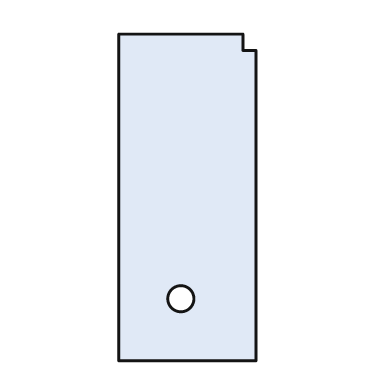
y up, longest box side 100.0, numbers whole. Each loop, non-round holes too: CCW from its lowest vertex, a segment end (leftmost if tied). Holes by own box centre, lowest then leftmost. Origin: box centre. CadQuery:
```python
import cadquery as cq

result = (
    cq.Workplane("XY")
    .moveTo(-21.0, -50.0)
    .lineTo(21.0, -50.0)
    .lineTo(21.0, 45.0)
    .lineTo(17.0, 45.0)
    .lineTo(17.0, 50.0)
    .lineTo(-21.0, 50.0)
    .close()
    .moveTo(-2.0, -31.0)
    .circle(4.0)
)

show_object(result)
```